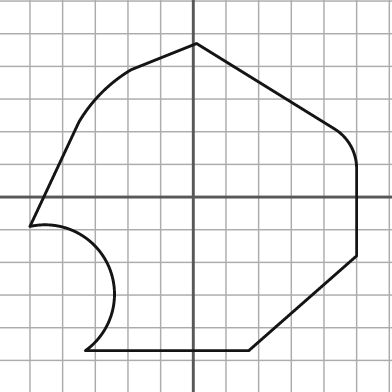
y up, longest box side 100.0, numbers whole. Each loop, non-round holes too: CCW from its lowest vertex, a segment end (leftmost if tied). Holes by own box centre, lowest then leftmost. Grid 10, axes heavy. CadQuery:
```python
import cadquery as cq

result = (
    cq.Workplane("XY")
    .moveTo(-33.0, -47.0)
    .lineTo(17.0, -47.0)
    .lineTo(50.0, -18.0)
    .lineTo(50.0, 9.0)
    .threePointArc((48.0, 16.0), (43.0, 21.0))
    .lineTo(1.0, 47.0)
    .lineTo(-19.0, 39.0)
    .threePointArc((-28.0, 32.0), (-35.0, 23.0))
    .lineTo(-50.0, -9.0)
    .threePointArc((-26.0, -21.0), (-33.0, -47.0))
    .close()
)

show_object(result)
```